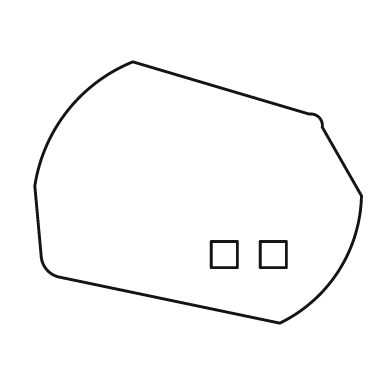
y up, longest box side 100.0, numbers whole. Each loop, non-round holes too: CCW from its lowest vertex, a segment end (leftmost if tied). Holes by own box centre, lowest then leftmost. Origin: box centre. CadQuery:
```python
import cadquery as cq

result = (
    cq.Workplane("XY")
    .moveTo(25.0, -40.0)
    .threePointArc((43.0, -24.0), (50.0, -1.0))
    .lineTo(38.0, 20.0)
    .threePointArc((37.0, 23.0), (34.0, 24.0))
    .lineTo(-20.0, 40.0)
    .threePointArc((-40.0, 25.0), (-50.0, 2.0))
    .lineTo(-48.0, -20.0)
    .threePointArc((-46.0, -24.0), (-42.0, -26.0))
    .close()
    .moveTo(4.0, -23.0)
    .lineTo(12.0, -23.0)
    .lineTo(12.0, -15.0)
    .lineTo(4.0, -15.0)
    .close()
    .moveTo(19.0, -23.0)
    .lineTo(27.0, -23.0)
    .lineTo(27.0, -15.0)
    .lineTo(19.0, -15.0)
    .close()
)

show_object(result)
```